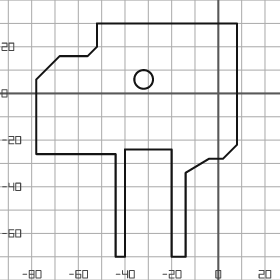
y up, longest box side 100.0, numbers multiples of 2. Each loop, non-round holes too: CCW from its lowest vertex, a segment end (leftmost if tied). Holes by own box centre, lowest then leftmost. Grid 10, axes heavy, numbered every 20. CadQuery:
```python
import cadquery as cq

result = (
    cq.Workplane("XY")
    .moveTo(-44.0, -70.0)
    .lineTo(-40.0, -70.0)
    .lineTo(-40.0, -24.0)
    .lineTo(-20.0, -24.0)
    .lineTo(-20.0, -70.0)
    .lineTo(-14.0, -70.0)
    .lineTo(-14.0, -34.0)
    .lineTo(-4.0, -28.0)
    .lineTo(2.0, -28.0)
    .lineTo(8.0, -22.0)
    .lineTo(8.0, 30.0)
    .lineTo(-52.0, 30.0)
    .lineTo(-52.0, 20.0)
    .lineTo(-56.0, 16.0)
    .lineTo(-68.0, 16.0)
    .lineTo(-78.0, 6.0)
    .lineTo(-78.0, -26.0)
    .lineTo(-44.0, -26.0)
    .close()
    .moveTo(-32.0, 6.0)
    .circle(4.0)
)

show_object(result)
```